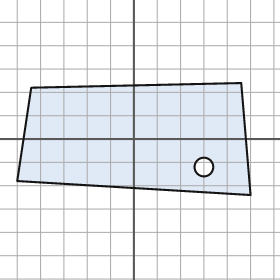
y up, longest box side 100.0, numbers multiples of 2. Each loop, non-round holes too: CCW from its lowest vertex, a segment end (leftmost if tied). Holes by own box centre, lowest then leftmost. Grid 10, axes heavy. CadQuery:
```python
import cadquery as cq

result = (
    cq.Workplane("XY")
    .moveTo(50.0, -24.0)
    .lineTo(46.0, 24.0)
    .lineTo(-44.0, 22.0)
    .lineTo(-50.0, -18.0)
    .close()
    .moveTo(30.0, -12.0)
    .circle(4.0)
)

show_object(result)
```